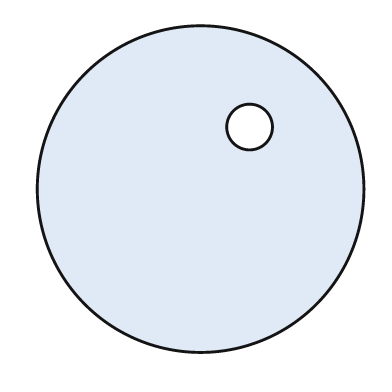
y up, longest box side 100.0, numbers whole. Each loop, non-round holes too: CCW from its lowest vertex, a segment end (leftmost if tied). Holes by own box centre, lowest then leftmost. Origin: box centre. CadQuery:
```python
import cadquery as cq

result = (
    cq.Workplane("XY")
    .moveTo(0.0, 0.0)
    .circle(50.0)
    .moveTo(15.0, 19.0)
    .circle(7.0)
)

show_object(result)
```